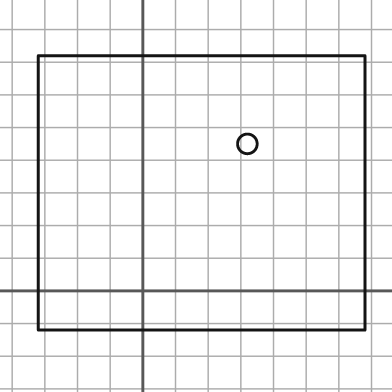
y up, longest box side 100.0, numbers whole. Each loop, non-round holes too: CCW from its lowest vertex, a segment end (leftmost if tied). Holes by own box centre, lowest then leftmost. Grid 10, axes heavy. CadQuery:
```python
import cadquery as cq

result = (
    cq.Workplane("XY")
    .moveTo(-32.0, -12.0)
    .lineTo(68.0, -12.0)
    .lineTo(68.0, 72.0)
    .lineTo(-32.0, 72.0)
    .close()
    .moveTo(32.0, 45.0)
    .circle(3.0)
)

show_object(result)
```